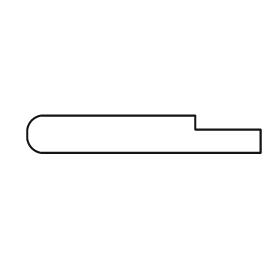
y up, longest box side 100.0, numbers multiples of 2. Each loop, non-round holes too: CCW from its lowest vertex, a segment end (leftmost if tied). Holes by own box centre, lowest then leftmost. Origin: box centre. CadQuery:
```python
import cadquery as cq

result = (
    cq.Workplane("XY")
    .moveTo(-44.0, -8.0)
    .lineTo(50.0, -8.0)
    .lineTo(50.0, 2.0)
    .lineTo(22.0, 2.0)
    .lineTo(22.0, 8.0)
    .lineTo(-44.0, 8.0)
    .threePointArc((-48.0, 6.0), (-50.0, 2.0))
    .lineTo(-50.0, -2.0)
    .threePointArc((-48.0, -6.0), (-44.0, -8.0))
    .close()
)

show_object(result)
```